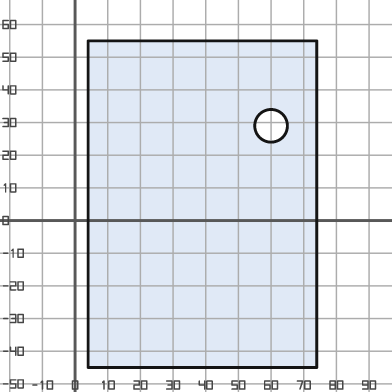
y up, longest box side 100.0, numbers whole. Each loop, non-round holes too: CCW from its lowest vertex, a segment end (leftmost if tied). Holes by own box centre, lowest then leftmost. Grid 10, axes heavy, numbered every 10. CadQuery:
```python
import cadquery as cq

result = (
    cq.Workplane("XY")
    .moveTo(4.0, -45.0)
    .lineTo(74.0, -45.0)
    .lineTo(74.0, 55.0)
    .lineTo(4.0, 55.0)
    .close()
    .moveTo(60.0, 29.0)
    .circle(5.0)
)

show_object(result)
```